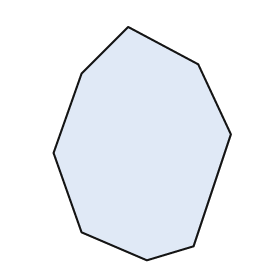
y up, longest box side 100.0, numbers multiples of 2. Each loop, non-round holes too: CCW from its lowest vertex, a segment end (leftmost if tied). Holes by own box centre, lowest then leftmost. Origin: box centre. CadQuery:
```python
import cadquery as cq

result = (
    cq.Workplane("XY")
    .moveTo(2.0, -50.0)
    .lineTo(22.0, -44.0)
    .lineTo(38.0, 4.0)
    .lineTo(24.0, 34.0)
    .lineTo(-6.0, 50.0)
    .lineTo(-26.0, 30.0)
    .lineTo(-38.0, -4.0)
    .lineTo(-26.0, -38.0)
    .close()
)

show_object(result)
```